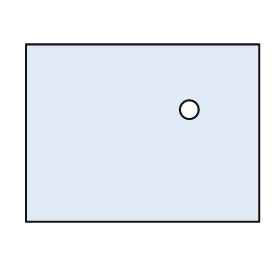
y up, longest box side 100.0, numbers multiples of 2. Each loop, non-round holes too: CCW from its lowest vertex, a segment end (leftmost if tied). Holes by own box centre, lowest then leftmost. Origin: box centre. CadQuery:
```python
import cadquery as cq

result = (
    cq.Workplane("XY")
    .moveTo(-50.0, -38.0)
    .lineTo(50.0, -38.0)
    .lineTo(50.0, 38.0)
    .lineTo(-50.0, 38.0)
    .close()
    .moveTo(20.0, 10.0)
    .circle(4.0)
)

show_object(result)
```